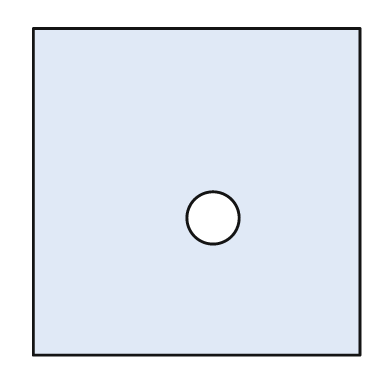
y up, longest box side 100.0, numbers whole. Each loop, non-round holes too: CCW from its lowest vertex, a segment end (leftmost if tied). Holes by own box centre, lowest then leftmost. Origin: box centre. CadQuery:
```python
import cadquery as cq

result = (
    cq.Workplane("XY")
    .moveTo(-50.0, -50.0)
    .lineTo(50.0, -50.0)
    .lineTo(50.0, 50.0)
    .lineTo(-50.0, 50.0)
    .close()
    .moveTo(5.0, -8.0)
    .circle(8.0)
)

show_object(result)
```